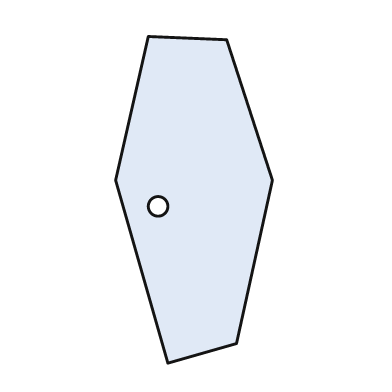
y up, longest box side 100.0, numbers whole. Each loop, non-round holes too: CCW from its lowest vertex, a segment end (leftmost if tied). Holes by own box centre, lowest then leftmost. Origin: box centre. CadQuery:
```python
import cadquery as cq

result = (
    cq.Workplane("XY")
    .moveTo(-8.0, -50.0)
    .lineTo(13.0, -44.0)
    .lineTo(24.0, 6.0)
    .lineTo(10.0, 49.0)
    .lineTo(-14.0, 50.0)
    .lineTo(-24.0, 6.0)
    .close()
    .moveTo(-11.0, -2.0)
    .circle(3.0)
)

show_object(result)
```